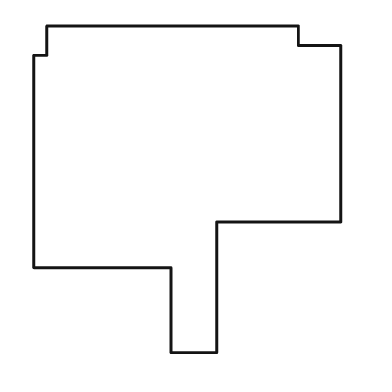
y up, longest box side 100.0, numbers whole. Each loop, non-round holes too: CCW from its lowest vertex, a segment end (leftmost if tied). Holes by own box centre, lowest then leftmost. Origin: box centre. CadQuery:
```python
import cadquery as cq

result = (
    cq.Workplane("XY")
    .moveTo(-5.0, -50.0)
    .lineTo(9.0, -50.0)
    .lineTo(9.0, -10.0)
    .lineTo(47.0, -10.0)
    .lineTo(47.0, 44.0)
    .lineTo(34.0, 44.0)
    .lineTo(34.0, 50.0)
    .lineTo(-43.0, 50.0)
    .lineTo(-43.0, 41.0)
    .lineTo(-47.0, 41.0)
    .lineTo(-47.0, -24.0)
    .lineTo(-5.0, -24.0)
    .close()
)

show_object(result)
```